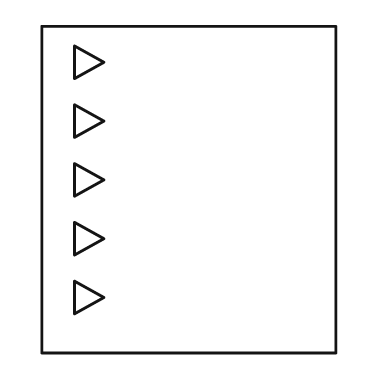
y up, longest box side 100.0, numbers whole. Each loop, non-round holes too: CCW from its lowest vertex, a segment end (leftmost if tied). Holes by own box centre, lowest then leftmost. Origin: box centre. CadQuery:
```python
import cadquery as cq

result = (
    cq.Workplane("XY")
    .moveTo(-45.0, -50.0)
    .lineTo(45.0, -50.0)
    .lineTo(45.0, 50.0)
    .lineTo(-45.0, 50.0)
    .close()
    .moveTo(-35.0, -38.0)
    .lineTo(-26.0, -33.0)
    .lineTo(-35.0, -28.0)
    .close()
    .moveTo(-35.0, -20.0)
    .lineTo(-26.0, -15.0)
    .lineTo(-35.0, -10.0)
    .close()
    .moveTo(-35.0, -2.0)
    .lineTo(-26.0, 3.0)
    .lineTo(-35.0, 8.0)
    .close()
    .moveTo(-35.0, 16.0)
    .lineTo(-26.0, 21.0)
    .lineTo(-35.0, 26.0)
    .close()
    .moveTo(-35.0, 34.0)
    .lineTo(-26.0, 39.0)
    .lineTo(-35.0, 44.0)
    .close()
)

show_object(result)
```